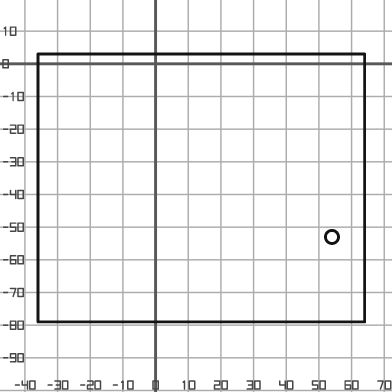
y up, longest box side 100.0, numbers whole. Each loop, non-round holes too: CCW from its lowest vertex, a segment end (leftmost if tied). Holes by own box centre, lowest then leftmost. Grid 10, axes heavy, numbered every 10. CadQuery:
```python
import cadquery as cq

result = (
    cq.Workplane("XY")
    .moveTo(-36.0, -79.0)
    .lineTo(64.0, -79.0)
    .lineTo(64.0, 3.0)
    .lineTo(-36.0, 3.0)
    .close()
    .moveTo(54.0, -53.0)
    .circle(2.0)
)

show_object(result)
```